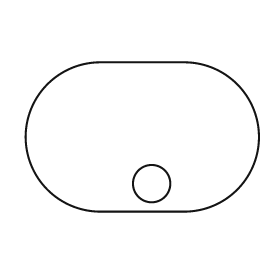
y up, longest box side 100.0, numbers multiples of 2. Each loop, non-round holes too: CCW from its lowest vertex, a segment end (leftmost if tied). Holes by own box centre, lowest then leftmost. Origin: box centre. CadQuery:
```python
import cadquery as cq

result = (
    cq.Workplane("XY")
    .moveTo(-18.0, -32.0)
    .lineTo(18.0, -32.0)
    .threePointArc((50.0, 0.0), (18.0, 32.0))
    .lineTo(-18.0, 32.0)
    .threePointArc((-50.0, 0.0), (-18.0, -32.0))
    .close()
    .moveTo(4.0, -20.0)
    .circle(8.0)
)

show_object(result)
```